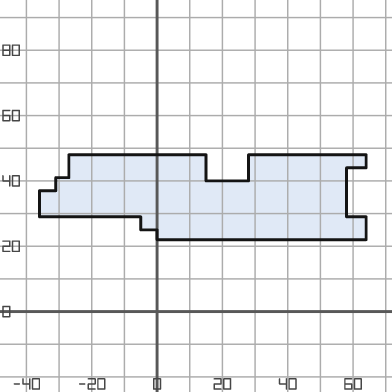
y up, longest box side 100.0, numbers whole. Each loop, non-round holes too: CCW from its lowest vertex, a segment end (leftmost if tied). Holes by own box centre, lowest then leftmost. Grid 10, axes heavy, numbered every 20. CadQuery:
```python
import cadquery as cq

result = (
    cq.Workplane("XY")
    .moveTo(0.0, 22.0)
    .lineTo(64.0, 22.0)
    .lineTo(64.0, 29.0)
    .lineTo(58.0, 29.0)
    .lineTo(58.0, 44.0)
    .lineTo(64.0, 44.0)
    .lineTo(64.0, 48.0)
    .lineTo(28.0, 48.0)
    .lineTo(28.0, 40.0)
    .lineTo(15.0, 40.0)
    .lineTo(15.0, 48.0)
    .lineTo(-27.0, 48.0)
    .lineTo(-27.0, 41.0)
    .lineTo(-31.0, 41.0)
    .lineTo(-31.0, 37.0)
    .lineTo(-36.0, 37.0)
    .lineTo(-36.0, 29.0)
    .lineTo(-5.0, 29.0)
    .lineTo(-5.0, 25.0)
    .lineTo(0.0, 25.0)
    .close()
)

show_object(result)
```